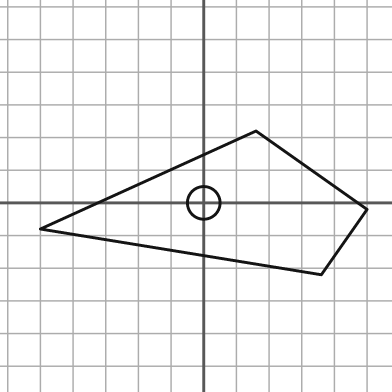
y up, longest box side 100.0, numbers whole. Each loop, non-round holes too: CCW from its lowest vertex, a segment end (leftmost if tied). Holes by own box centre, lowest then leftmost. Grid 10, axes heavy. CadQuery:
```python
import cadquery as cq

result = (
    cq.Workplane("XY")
    .moveTo(36.0, -22.0)
    .lineTo(50.0, -2.0)
    .lineTo(16.0, 22.0)
    .lineTo(-50.0, -8.0)
    .close()
    .moveTo(0.0, 0.0)
    .circle(5.0)
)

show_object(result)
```